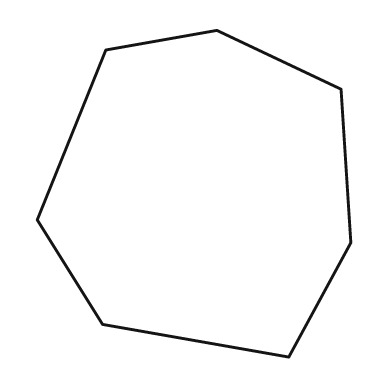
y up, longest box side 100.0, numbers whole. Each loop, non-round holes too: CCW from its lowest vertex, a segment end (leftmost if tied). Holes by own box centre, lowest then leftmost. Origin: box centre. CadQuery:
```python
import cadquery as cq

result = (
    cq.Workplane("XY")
    .moveTo(29.0, -50.0)
    .lineTo(48.0, -15.0)
    .lineTo(45.0, 32.0)
    .lineTo(7.0, 50.0)
    .lineTo(-27.0, 44.0)
    .lineTo(-48.0, -8.0)
    .lineTo(-28.0, -40.0)
    .close()
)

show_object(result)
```